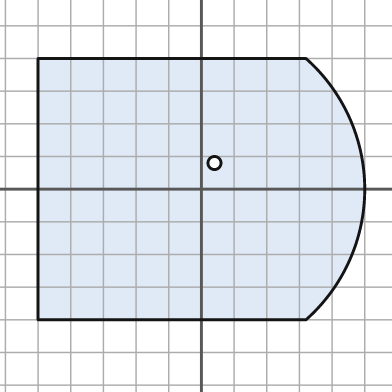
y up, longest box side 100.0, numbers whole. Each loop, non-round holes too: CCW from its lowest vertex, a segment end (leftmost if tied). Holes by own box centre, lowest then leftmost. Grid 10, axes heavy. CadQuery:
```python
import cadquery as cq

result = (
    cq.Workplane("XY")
    .moveTo(-50.0, -40.0)
    .lineTo(32.0, -40.0)
    .threePointArc((50.0, 0.0), (32.0, 40.0))
    .lineTo(-50.0, 40.0)
    .close()
    .moveTo(4.0, 8.0)
    .circle(2.0)
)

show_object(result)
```